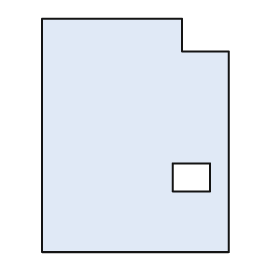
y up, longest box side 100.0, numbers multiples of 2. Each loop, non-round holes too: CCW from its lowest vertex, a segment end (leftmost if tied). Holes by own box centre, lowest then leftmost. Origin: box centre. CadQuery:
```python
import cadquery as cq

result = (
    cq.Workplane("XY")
    .moveTo(-40.0, -50.0)
    .lineTo(40.0, -50.0)
    .lineTo(40.0, 36.0)
    .lineTo(20.0, 36.0)
    .lineTo(20.0, 50.0)
    .lineTo(-40.0, 50.0)
    .close()
    .moveTo(16.0, -24.0)
    .lineTo(32.0, -24.0)
    .lineTo(32.0, -12.0)
    .lineTo(16.0, -12.0)
    .close()
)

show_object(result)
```